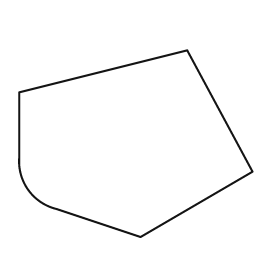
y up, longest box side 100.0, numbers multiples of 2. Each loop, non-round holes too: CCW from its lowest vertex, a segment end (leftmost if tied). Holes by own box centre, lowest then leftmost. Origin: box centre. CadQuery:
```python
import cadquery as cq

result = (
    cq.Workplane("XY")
    .moveTo(2.0, -40.0)
    .lineTo(50.0, -12.0)
    .lineTo(22.0, 40.0)
    .lineTo(-50.0, 22.0)
    .lineTo(-50.0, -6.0)
    .threePointArc((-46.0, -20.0), (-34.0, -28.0))
    .close()
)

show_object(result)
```